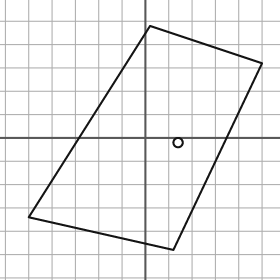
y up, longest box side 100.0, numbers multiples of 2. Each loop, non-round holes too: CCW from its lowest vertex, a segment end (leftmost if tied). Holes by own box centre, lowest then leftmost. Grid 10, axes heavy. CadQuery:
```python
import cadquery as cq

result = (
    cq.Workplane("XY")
    .moveTo(12.0, -48.0)
    .lineTo(50.0, 32.0)
    .lineTo(2.0, 48.0)
    .lineTo(-50.0, -34.0)
    .close()
    .moveTo(14.0, -2.0)
    .circle(2.0)
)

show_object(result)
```